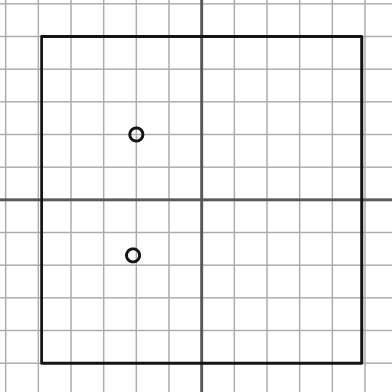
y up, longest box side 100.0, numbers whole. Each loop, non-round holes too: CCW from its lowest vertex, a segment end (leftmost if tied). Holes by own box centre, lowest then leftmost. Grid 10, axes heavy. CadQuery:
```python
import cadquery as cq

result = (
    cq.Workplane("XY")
    .moveTo(-49.0, -50.0)
    .lineTo(49.0, -50.0)
    .lineTo(49.0, 50.0)
    .lineTo(-49.0, 50.0)
    .close()
    .moveTo(-21.0, -17.0)
    .circle(2.0)
    .moveTo(-20.0, 20.0)
    .circle(2.0)
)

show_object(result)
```